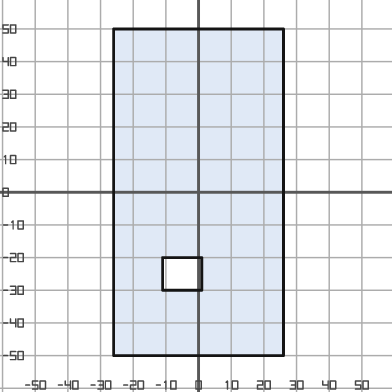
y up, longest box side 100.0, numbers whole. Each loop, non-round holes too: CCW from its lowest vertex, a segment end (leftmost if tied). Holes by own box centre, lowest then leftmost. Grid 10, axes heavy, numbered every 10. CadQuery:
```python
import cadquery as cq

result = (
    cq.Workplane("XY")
    .moveTo(-26.0, -50.0)
    .lineTo(26.0, -50.0)
    .lineTo(26.0, 50.0)
    .lineTo(-26.0, 50.0)
    .close()
    .moveTo(-11.0, -30.0)
    .lineTo(1.0, -30.0)
    .lineTo(1.0, -20.0)
    .lineTo(-11.0, -20.0)
    .close()
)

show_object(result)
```